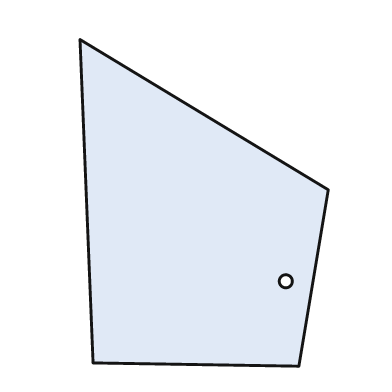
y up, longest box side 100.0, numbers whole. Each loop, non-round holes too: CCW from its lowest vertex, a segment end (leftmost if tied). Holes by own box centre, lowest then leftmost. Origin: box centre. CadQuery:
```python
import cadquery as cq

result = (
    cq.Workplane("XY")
    .moveTo(29.0, -50.0)
    .lineTo(38.0, 4.0)
    .lineTo(-38.0, 50.0)
    .lineTo(-34.0, -49.0)
    .close()
    .moveTo(25.0, -24.0)
    .circle(2.0)
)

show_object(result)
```